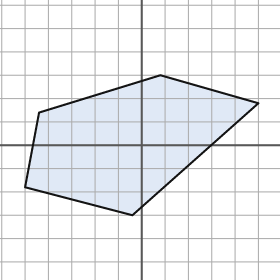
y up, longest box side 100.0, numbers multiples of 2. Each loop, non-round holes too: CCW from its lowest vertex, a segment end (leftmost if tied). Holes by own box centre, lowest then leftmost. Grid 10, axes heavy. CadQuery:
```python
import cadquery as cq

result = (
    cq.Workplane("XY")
    .moveTo(-4.0, -30.0)
    .lineTo(50.0, 18.0)
    .lineTo(8.0, 30.0)
    .lineTo(-44.0, 14.0)
    .lineTo(-50.0, -18.0)
    .close()
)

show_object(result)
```